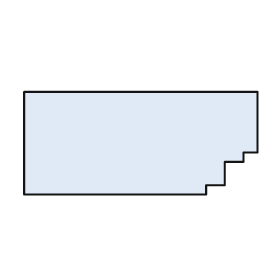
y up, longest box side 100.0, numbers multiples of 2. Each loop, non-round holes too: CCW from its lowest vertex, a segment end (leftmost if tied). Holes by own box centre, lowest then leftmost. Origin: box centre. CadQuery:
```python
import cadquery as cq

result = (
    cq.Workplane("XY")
    .moveTo(-50.0, -22.0)
    .lineTo(28.0, -22.0)
    .lineTo(28.0, -18.0)
    .lineTo(36.0, -18.0)
    .lineTo(36.0, -8.0)
    .lineTo(44.0, -8.0)
    .lineTo(44.0, -4.0)
    .lineTo(50.0, -4.0)
    .lineTo(50.0, 22.0)
    .lineTo(-50.0, 22.0)
    .close()
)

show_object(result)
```